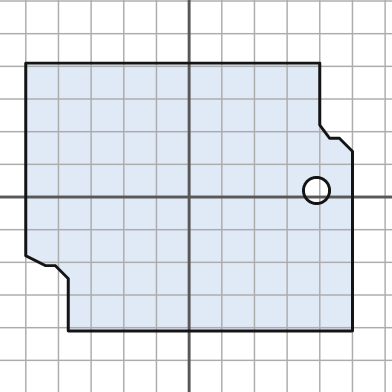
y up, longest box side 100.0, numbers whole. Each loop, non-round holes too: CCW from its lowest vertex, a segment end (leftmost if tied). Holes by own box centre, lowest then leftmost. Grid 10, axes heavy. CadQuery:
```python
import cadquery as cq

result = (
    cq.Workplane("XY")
    .moveTo(-37.0, -41.0)
    .lineTo(50.0, -41.0)
    .lineTo(50.0, 14.0)
    .lineTo(46.0, 18.0)
    .lineTo(43.0, 18.0)
    .lineTo(40.0, 22.0)
    .lineTo(40.0, 41.0)
    .lineTo(-50.0, 41.0)
    .lineTo(-50.0, -18.0)
    .lineTo(-44.0, -21.0)
    .lineTo(-41.0, -21.0)
    .lineTo(-37.0, -25.0)
    .close()
    .moveTo(39.0, 2.0)
    .circle(4.0)
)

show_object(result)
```